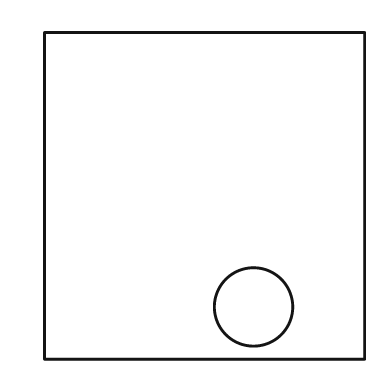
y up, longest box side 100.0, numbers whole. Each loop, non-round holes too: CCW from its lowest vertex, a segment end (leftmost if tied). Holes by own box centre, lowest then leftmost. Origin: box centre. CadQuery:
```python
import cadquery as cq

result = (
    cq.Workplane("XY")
    .moveTo(-49.0, -50.0)
    .lineTo(49.0, -50.0)
    .lineTo(49.0, 50.0)
    .lineTo(-49.0, 50.0)
    .close()
    .moveTo(15.0, -34.0)
    .circle(12.0)
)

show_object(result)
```